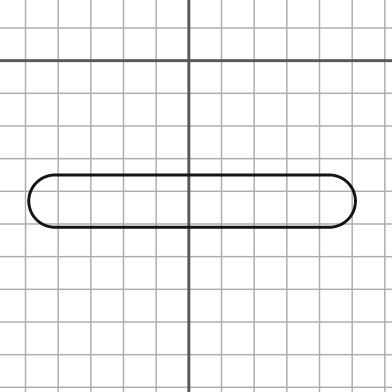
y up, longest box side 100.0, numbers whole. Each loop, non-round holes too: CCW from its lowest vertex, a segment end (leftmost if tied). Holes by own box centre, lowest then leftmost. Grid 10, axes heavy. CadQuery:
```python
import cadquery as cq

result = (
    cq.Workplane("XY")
    .moveTo(-41.0, -51.0)
    .lineTo(43.0, -51.0)
    .threePointArc((51.0, -43.0), (43.0, -35.0))
    .lineTo(-41.0, -35.0)
    .threePointArc((-49.0, -43.0), (-41.0, -51.0))
    .close()
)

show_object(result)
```